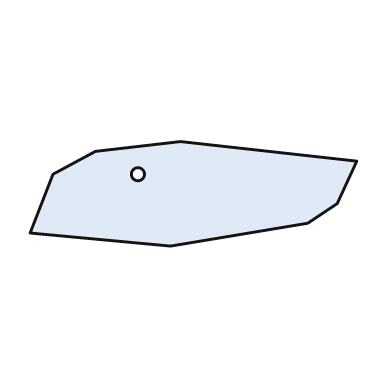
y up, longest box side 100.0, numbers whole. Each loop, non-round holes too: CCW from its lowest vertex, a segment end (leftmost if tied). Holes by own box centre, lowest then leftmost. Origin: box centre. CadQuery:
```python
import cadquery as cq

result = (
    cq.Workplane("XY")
    .moveTo(-7.0, -16.0)
    .lineTo(35.0, -9.0)
    .lineTo(44.0, -3.0)
    .lineTo(50.0, 10.0)
    .lineTo(-4.0, 16.0)
    .lineTo(-30.0, 13.0)
    .lineTo(-43.0, 6.0)
    .lineTo(-50.0, -12.0)
    .close()
    .moveTo(-17.0, 6.0)
    .circle(2.0)
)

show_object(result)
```